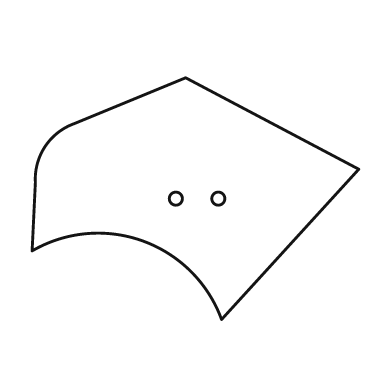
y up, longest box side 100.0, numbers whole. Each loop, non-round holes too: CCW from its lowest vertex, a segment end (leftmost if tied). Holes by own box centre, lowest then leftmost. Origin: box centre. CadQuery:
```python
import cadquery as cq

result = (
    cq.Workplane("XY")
    .moveTo(8.0, -37.0)
    .lineTo(50.0, 9.0)
    .lineTo(-3.0, 37.0)
    .lineTo(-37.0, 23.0)
    .threePointArc((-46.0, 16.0), (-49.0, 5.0))
    .lineTo(-50.0, -16.0)
    .threePointArc((-16.0, -13.0), (8.0, -37.0))
    .close()
    .moveTo(-6.0, 0.0)
    .circle(2.0)
    .moveTo(7.0, 0.0)
    .circle(2.0)
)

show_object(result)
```